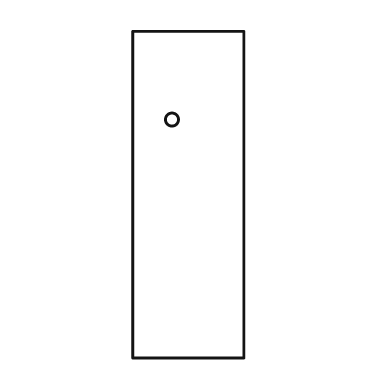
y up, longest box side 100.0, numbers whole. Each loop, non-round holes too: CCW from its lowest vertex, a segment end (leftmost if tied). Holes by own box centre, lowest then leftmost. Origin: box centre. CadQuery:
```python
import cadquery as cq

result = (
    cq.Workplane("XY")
    .moveTo(-17.0, -50.0)
    .lineTo(17.0, -50.0)
    .lineTo(17.0, 50.0)
    .lineTo(-17.0, 50.0)
    .close()
    .moveTo(-5.0, 23.0)
    .circle(2.0)
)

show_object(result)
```